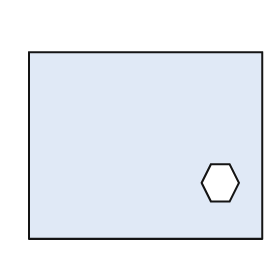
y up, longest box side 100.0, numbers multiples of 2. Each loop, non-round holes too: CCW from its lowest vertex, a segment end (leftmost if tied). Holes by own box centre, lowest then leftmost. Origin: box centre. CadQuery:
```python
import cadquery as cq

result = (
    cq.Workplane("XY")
    .moveTo(-50.0, -40.0)
    .lineTo(50.0, -40.0)
    .lineTo(50.0, 40.0)
    .lineTo(-50.0, 40.0)
    .close()
    .moveTo(28.0, -24.0)
    .lineTo(36.0, -24.0)
    .lineTo(40.0, -16.0)
    .lineTo(36.0, -8.0)
    .lineTo(28.0, -8.0)
    .lineTo(24.0, -16.0)
    .close()
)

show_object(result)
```